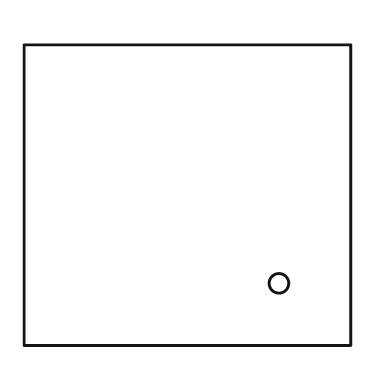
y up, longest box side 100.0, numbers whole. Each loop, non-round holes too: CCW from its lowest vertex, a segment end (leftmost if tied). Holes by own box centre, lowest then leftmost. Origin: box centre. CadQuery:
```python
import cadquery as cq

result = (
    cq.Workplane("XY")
    .moveTo(-50.0, -46.0)
    .lineTo(50.0, -46.0)
    .lineTo(50.0, 46.0)
    .lineTo(-50.0, 46.0)
    .close()
    .moveTo(28.0, -27.0)
    .circle(3.0)
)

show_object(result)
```